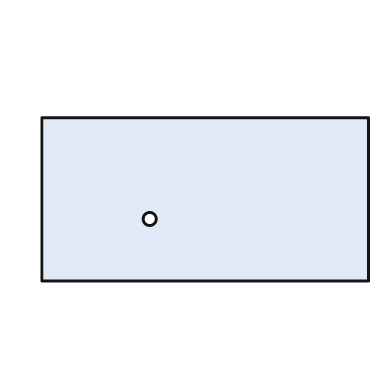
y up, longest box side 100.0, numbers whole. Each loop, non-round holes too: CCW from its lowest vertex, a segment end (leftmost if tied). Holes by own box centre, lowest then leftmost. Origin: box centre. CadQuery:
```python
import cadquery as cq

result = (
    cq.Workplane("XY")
    .moveTo(-50.0, -25.0)
    .lineTo(50.0, -25.0)
    .lineTo(50.0, 25.0)
    .lineTo(-50.0, 25.0)
    .close()
    .moveTo(-17.0, -6.0)
    .circle(2.0)
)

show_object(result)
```